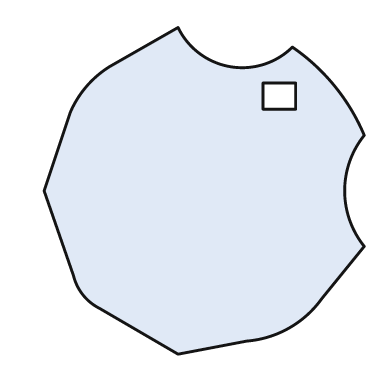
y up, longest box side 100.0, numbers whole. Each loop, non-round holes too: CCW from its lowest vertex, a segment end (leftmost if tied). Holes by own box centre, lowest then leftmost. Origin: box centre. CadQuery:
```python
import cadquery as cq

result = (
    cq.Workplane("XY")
    .moveTo(-8.0, -50.0)
    .lineTo(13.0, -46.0)
    .threePointArc((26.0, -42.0), (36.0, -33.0))
    .lineTo(49.0, -17.0)
    .threePointArc((43.0, 0.0), (49.0, 17.0))
    .threePointArc((40.0, 32.0), (27.0, 44.0))
    .threePointArc((8.0, 38.0), (-8.0, 50.0))
    .lineTo(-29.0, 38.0)
    .threePointArc((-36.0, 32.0), (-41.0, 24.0))
    .lineTo(-49.0, 0.0)
    .lineTo(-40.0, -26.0)
    .threePointArc((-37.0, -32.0), (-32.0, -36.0))
    .close()
    .moveTo(18.0, 25.0)
    .lineTo(28.0, 25.0)
    .lineTo(28.0, 33.0)
    .lineTo(18.0, 33.0)
    .close()
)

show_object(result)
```